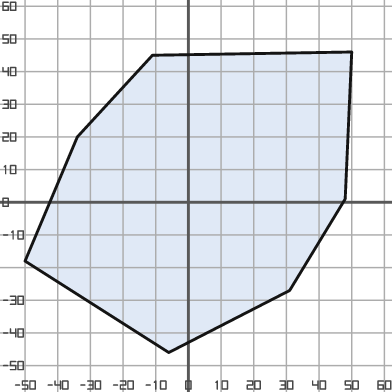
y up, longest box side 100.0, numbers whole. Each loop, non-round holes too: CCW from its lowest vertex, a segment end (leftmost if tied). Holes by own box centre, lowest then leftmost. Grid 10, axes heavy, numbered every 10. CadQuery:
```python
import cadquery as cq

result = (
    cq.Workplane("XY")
    .moveTo(-6.0, -46.0)
    .lineTo(31.0, -27.0)
    .lineTo(48.0, 1.0)
    .lineTo(50.0, 46.0)
    .lineTo(-11.0, 45.0)
    .lineTo(-34.0, 20.0)
    .lineTo(-50.0, -18.0)
    .close()
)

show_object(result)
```